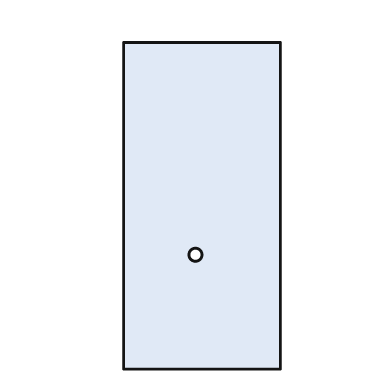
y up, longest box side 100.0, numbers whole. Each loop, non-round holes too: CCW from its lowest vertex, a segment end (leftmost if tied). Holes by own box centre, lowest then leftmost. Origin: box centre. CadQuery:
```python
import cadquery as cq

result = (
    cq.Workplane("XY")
    .moveTo(-24.0, -50.0)
    .lineTo(24.0, -50.0)
    .lineTo(24.0, 50.0)
    .lineTo(-24.0, 50.0)
    .close()
    .moveTo(-2.0, -15.0)
    .circle(2.0)
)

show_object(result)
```